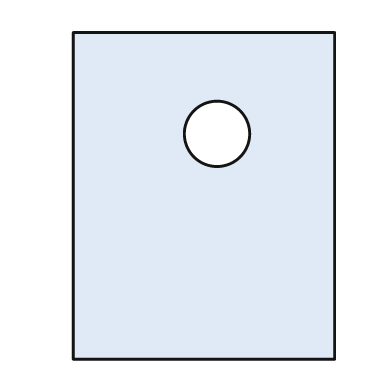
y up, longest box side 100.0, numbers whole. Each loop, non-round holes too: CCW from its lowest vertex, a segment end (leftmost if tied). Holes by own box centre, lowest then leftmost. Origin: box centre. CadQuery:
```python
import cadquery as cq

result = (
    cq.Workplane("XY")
    .moveTo(-40.0, -50.0)
    .lineTo(40.0, -50.0)
    .lineTo(40.0, 50.0)
    .lineTo(-40.0, 50.0)
    .close()
    .moveTo(4.0, 19.0)
    .circle(10.0)
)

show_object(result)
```